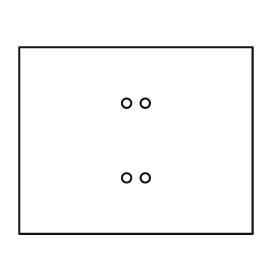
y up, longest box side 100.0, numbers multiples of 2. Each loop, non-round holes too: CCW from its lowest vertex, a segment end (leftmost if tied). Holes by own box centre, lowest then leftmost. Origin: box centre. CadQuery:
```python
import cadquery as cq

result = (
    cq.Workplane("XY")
    .moveTo(-50.0, -40.0)
    .lineTo(50.0, -40.0)
    .lineTo(50.0, 40.0)
    .lineTo(-50.0, 40.0)
    .close()
    .moveTo(-4.0, -16.0)
    .circle(2.0)
    .moveTo(4.0, -16.0)
    .circle(2.0)
    .moveTo(-4.0, 16.0)
    .circle(2.0)
    .moveTo(4.0, 16.0)
    .circle(2.0)
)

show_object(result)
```